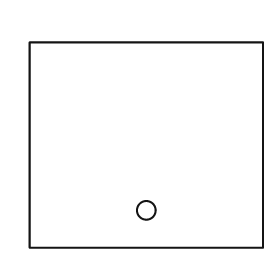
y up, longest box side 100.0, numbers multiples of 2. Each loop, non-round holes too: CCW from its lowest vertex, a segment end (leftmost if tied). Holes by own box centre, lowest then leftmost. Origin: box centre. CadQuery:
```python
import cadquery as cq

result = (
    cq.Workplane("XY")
    .moveTo(-50.0, -44.0)
    .lineTo(50.0, -44.0)
    .lineTo(50.0, 44.0)
    .lineTo(-50.0, 44.0)
    .close()
    .moveTo(0.0, -28.0)
    .circle(4.0)
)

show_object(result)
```